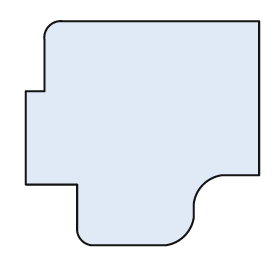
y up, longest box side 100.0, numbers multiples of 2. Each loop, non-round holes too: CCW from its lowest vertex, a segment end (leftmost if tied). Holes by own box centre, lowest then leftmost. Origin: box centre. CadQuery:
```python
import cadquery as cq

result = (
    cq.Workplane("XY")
    .moveTo(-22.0, -48.0)
    .lineTo(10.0, -48.0)
    .threePointArc((18.0, -44.0), (22.0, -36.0))
    .lineTo(22.0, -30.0)
    .threePointArc((26.0, -22.0), (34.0, -18.0))
    .lineTo(50.0, -18.0)
    .lineTo(50.0, 48.0)
    .lineTo(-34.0, 48.0)
    .threePointArc((-40.0, 46.0), (-42.0, 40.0))
    .lineTo(-42.0, 18.0)
    .lineTo(-50.0, 18.0)
    .lineTo(-50.0, -22.0)
    .lineTo(-28.0, -22.0)
    .lineTo(-28.0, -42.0)
    .threePointArc((-26.0, -46.0), (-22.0, -48.0))
    .close()
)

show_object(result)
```